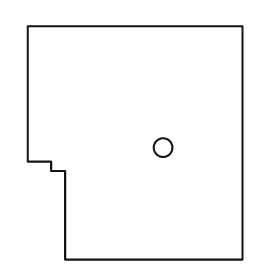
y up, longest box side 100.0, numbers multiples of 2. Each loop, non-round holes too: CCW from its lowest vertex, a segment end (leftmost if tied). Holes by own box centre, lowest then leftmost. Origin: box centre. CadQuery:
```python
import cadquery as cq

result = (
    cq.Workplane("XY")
    .moveTo(-30.0, -50.0)
    .lineTo(46.0, -50.0)
    .lineTo(46.0, 50.0)
    .lineTo(-46.0, 50.0)
    .lineTo(-46.0, -8.0)
    .lineTo(-36.0, -8.0)
    .lineTo(-36.0, -12.0)
    .lineTo(-30.0, -12.0)
    .close()
    .moveTo(12.0, -2.0)
    .circle(4.0)
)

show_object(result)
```